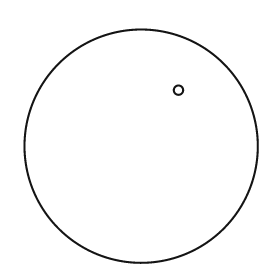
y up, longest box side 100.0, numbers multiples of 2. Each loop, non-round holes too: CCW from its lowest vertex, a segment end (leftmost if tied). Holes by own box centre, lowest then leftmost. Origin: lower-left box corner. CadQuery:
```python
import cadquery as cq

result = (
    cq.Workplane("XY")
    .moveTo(50.0, 50.0)
    .circle(50.0)
    .moveTo(66.0, 74.0)
    .circle(2.0)
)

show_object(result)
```